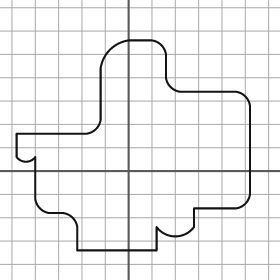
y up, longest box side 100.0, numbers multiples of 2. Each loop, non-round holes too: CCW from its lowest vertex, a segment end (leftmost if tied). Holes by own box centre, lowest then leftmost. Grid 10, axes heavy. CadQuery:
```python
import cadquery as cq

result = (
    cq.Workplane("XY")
    .moveTo(-22.0, -34.0)
    .lineTo(12.0, -34.0)
    .lineTo(12.0, -24.0)
    .threePointArc((20.0, -28.0), (28.0, -24.0))
    .lineTo(28.0, -16.0)
    .lineTo(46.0, -16.0)
    .threePointArc((50.0, -14.0), (52.0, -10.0))
    .lineTo(52.0, 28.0)
    .threePointArc((50.0, 32.0), (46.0, 34.0))
    .lineTo(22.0, 34.0)
    .threePointArc((18.0, 36.0), (16.0, 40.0))
    .lineTo(16.0, 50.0)
    .threePointArc((14.0, 54.0), (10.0, 56.0))
    .lineTo(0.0, 56.0)
    .threePointArc((-8.0, 52.0), (-12.0, 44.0))
    .lineTo(-12.0, 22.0)
    .threePointArc((-14.0, 18.0), (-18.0, 16.0))
    .lineTo(-48.0, 16.0)
    .lineTo(-48.0, 6.0)
    .threePointArc((-44.0, 4.0), (-40.0, 6.0))
    .lineTo(-40.0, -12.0)
    .threePointArc((-38.0, -16.0), (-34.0, -18.0))
    .lineTo(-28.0, -18.0)
    .threePointArc((-24.0, -20.0), (-22.0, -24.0))
    .close()
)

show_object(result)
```